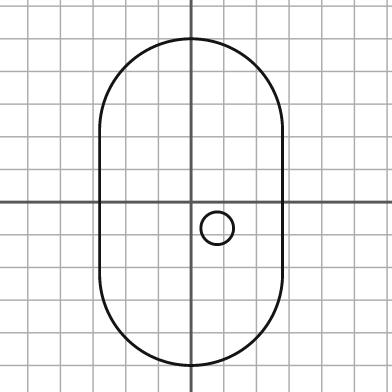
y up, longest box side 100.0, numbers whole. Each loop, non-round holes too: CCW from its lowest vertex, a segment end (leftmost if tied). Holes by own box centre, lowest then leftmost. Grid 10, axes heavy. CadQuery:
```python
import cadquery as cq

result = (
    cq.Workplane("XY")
    .moveTo(-28.0, -22.0)
    .threePointArc((0.0, -50.0), (28.0, -22.0))
    .lineTo(28.0, 22.0)
    .threePointArc((0.0, 50.0), (-28.0, 22.0))
    .close()
    .moveTo(8.0, -8.0)
    .circle(5.0)
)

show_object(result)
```